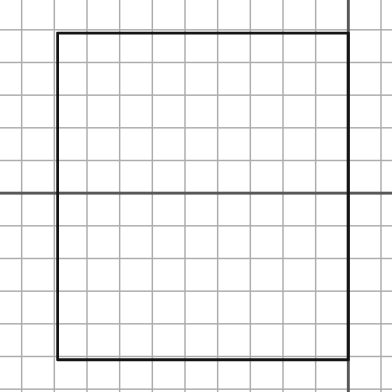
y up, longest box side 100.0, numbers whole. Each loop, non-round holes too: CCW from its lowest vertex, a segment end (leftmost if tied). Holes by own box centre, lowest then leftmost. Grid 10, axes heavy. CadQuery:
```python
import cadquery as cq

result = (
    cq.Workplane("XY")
    .moveTo(-89.0, -51.0)
    .lineTo(0.0, -51.0)
    .lineTo(0.0, 49.0)
    .lineTo(-89.0, 49.0)
    .close()
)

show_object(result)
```